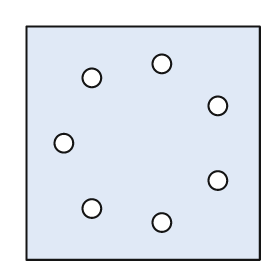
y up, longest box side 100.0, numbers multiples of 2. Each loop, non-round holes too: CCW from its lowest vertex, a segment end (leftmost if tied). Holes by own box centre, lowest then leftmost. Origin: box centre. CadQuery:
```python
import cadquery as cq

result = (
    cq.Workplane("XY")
    .moveTo(-50.0, -50.0)
    .lineTo(50.0, -50.0)
    .lineTo(50.0, 50.0)
    .lineTo(-50.0, 50.0)
    .close()
    .moveTo(8.0, -34.0)
    .circle(4.0)
    .moveTo(-22.0, -28.0)
    .circle(4.0)
    .moveTo(32.0, -16.0)
    .circle(4.0)
    .moveTo(-34.0, 0.0)
    .circle(4.0)
    .moveTo(32.0, 16.0)
    .circle(4.0)
    .moveTo(-22.0, 28.0)
    .circle(4.0)
    .moveTo(8.0, 34.0)
    .circle(4.0)
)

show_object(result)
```